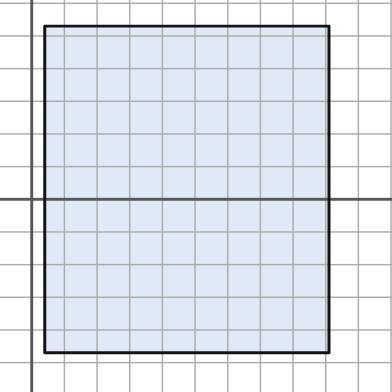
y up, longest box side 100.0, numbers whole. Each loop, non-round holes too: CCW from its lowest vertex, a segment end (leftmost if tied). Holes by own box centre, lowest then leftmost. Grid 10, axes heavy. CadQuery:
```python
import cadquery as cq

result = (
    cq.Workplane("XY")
    .moveTo(4.0, -47.0)
    .lineTo(91.0, -47.0)
    .lineTo(91.0, 53.0)
    .lineTo(4.0, 53.0)
    .close()
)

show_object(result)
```